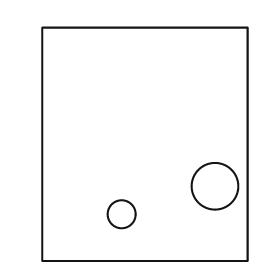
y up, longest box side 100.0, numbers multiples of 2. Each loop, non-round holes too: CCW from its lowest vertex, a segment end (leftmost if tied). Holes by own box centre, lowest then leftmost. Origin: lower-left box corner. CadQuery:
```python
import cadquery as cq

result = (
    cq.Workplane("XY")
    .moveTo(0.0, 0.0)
    .lineTo(88.0, 0.0)
    .lineTo(88.0, 100.0)
    .lineTo(0.0, 100.0)
    .close()
    .moveTo(34.0, 20.0)
    .circle(6.0)
    .moveTo(74.0, 32.0)
    .circle(10.0)
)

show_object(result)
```